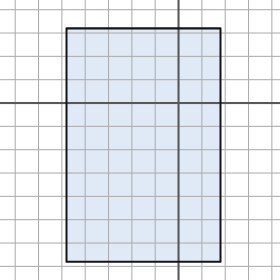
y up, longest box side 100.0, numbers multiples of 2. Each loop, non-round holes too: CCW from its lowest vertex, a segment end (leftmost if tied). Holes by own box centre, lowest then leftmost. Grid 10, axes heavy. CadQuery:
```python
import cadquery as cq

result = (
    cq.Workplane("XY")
    .moveTo(-48.0, -68.0)
    .lineTo(18.0, -68.0)
    .lineTo(18.0, 32.0)
    .lineTo(-48.0, 32.0)
    .close()
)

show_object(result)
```